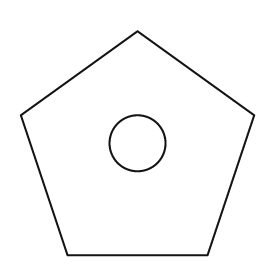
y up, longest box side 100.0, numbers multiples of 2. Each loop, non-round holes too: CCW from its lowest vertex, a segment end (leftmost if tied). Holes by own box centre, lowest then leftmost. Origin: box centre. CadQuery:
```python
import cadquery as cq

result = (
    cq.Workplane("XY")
    .moveTo(-30.0, -48.0)
    .lineTo(30.0, -48.0)
    .lineTo(50.0, 12.0)
    .lineTo(0.0, 48.0)
    .lineTo(-50.0, 12.0)
    .close()
    .moveTo(0.0, 0.0)
    .circle(12.0)
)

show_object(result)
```